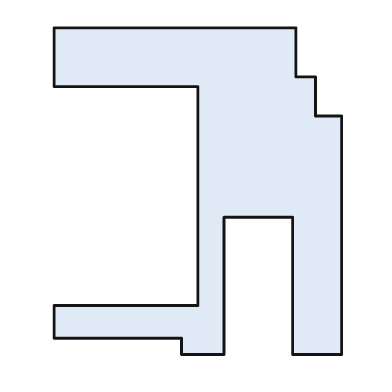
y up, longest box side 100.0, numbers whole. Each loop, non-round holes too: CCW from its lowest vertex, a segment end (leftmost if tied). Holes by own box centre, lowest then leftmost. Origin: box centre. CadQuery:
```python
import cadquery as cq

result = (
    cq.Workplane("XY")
    .moveTo(-5.0, -50.0)
    .lineTo(8.0, -50.0)
    .lineTo(8.0, -8.0)
    .lineTo(29.0, -8.0)
    .lineTo(29.0, -50.0)
    .lineTo(44.0, -50.0)
    .lineTo(44.0, 23.0)
    .lineTo(36.0, 23.0)
    .lineTo(36.0, 35.0)
    .lineTo(30.0, 35.0)
    .lineTo(30.0, 50.0)
    .lineTo(-44.0, 50.0)
    .lineTo(-44.0, 32.0)
    .lineTo(0.0, 32.0)
    .lineTo(0.0, -35.0)
    .lineTo(-44.0, -35.0)
    .lineTo(-44.0, -45.0)
    .lineTo(-5.0, -45.0)
    .close()
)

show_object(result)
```